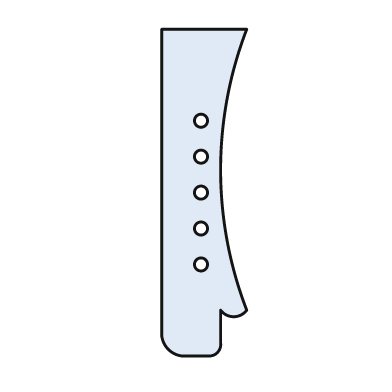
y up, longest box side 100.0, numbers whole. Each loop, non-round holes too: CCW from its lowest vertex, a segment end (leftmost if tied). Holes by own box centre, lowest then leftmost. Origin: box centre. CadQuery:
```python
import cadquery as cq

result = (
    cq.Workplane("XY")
    .moveTo(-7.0, -50.0)
    .lineTo(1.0, -50.0)
    .threePointArc((4.0, -49.0), (5.0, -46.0))
    .lineTo(5.0, -36.0)
    .threePointArc((9.0, -38.0), (13.0, -36.0))
    .threePointArc((5.0, 7.0), (13.0, 50.0))
    .lineTo(-13.0, 50.0)
    .lineTo(-13.0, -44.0)
    .threePointArc((-11.0, -48.0), (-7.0, -50.0))
    .close()
    .moveTo(-1.0, -22.0)
    .circle(2.0)
    .moveTo(-1.0, -11.0)
    .circle(2.0)
    .moveTo(-1.0, 0.0)
    .circle(2.0)
    .moveTo(-1.0, 11.0)
    .circle(2.0)
    .moveTo(-1.0, 22.0)
    .circle(2.0)
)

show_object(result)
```